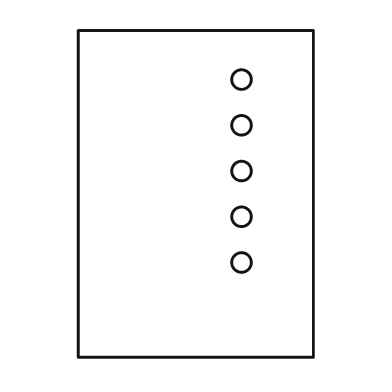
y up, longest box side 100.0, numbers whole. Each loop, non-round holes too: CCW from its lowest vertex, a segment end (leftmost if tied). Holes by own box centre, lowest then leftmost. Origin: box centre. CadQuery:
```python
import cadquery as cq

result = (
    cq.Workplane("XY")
    .moveTo(-36.0, -50.0)
    .lineTo(36.0, -50.0)
    .lineTo(36.0, 50.0)
    .lineTo(-36.0, 50.0)
    .close()
    .moveTo(14.0, -21.0)
    .circle(3.0)
    .moveTo(14.0, -7.0)
    .circle(3.0)
    .moveTo(14.0, 7.0)
    .circle(3.0)
    .moveTo(14.0, 21.0)
    .circle(3.0)
    .moveTo(14.0, 35.0)
    .circle(3.0)
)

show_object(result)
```